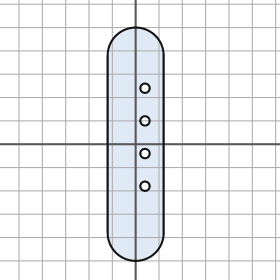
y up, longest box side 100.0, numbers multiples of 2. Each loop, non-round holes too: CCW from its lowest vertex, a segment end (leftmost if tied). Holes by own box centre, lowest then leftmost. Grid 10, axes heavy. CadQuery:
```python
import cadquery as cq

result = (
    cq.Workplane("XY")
    .moveTo(-12.0, -38.0)
    .threePointArc((0.0, -50.0), (12.0, -38.0))
    .lineTo(12.0, 38.0)
    .threePointArc((0.0, 50.0), (-12.0, 38.0))
    .close()
    .moveTo(4.0, -18.0)
    .circle(2.0)
    .moveTo(4.0, -4.0)
    .circle(2.0)
    .moveTo(4.0, 10.0)
    .circle(2.0)
    .moveTo(4.0, 24.0)
    .circle(2.0)
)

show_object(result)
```